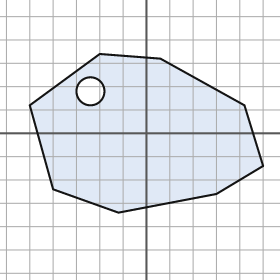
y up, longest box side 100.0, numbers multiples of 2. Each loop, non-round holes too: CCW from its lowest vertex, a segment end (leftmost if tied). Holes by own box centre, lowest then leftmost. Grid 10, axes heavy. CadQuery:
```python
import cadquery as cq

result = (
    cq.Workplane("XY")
    .moveTo(-12.0, -34.0)
    .lineTo(30.0, -26.0)
    .lineTo(50.0, -14.0)
    .lineTo(42.0, 12.0)
    .lineTo(6.0, 32.0)
    .lineTo(-20.0, 34.0)
    .lineTo(-50.0, 12.0)
    .lineTo(-40.0, -24.0)
    .close()
    .moveTo(-24.0, 18.0)
    .circle(6.0)
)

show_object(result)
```